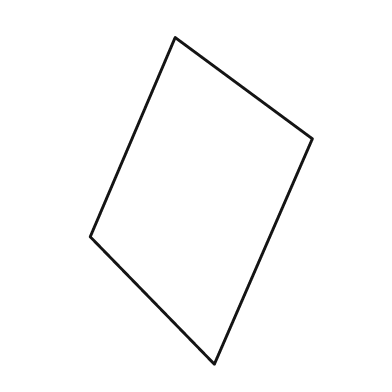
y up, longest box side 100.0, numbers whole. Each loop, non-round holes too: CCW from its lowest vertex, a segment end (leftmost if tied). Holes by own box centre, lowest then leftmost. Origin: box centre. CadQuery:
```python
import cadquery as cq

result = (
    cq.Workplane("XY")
    .moveTo(4.0, -50.0)
    .lineTo(34.0, 19.0)
    .lineTo(-8.0, 50.0)
    .lineTo(-34.0, -11.0)
    .close()
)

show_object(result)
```